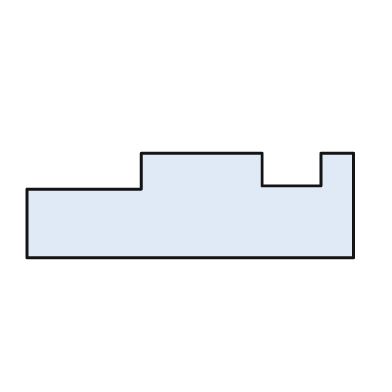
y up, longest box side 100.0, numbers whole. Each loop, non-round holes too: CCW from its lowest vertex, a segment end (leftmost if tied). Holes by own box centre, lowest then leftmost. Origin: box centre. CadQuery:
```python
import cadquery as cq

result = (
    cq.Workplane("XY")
    .moveTo(-50.0, -16.0)
    .lineTo(50.0, -16.0)
    .lineTo(50.0, 16.0)
    .lineTo(40.0, 16.0)
    .lineTo(40.0, 6.0)
    .lineTo(22.0, 6.0)
    .lineTo(22.0, 16.0)
    .lineTo(-15.0, 16.0)
    .lineTo(-15.0, 5.0)
    .lineTo(-50.0, 5.0)
    .close()
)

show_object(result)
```